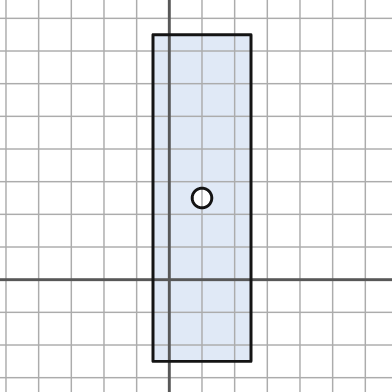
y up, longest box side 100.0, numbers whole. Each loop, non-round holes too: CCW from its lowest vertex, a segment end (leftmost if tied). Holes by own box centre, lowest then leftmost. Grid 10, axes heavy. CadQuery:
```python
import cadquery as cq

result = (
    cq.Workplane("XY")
    .moveTo(-5.0, -25.0)
    .lineTo(25.0, -25.0)
    .lineTo(25.0, 75.0)
    .lineTo(-5.0, 75.0)
    .close()
    .moveTo(10.0, 25.0)
    .circle(3.0)
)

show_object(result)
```